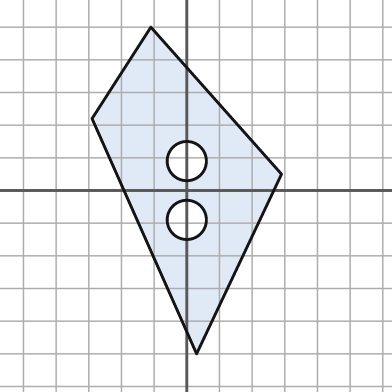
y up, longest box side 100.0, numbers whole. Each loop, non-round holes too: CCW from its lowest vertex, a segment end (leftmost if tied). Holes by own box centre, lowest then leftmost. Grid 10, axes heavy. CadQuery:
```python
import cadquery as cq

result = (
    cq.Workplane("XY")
    .moveTo(3.0, -50.0)
    .lineTo(29.0, 5.0)
    .lineTo(-11.0, 50.0)
    .lineTo(-29.0, 22.0)
    .close()
    .moveTo(0.0, -9.0)
    .circle(6.0)
    .moveTo(0.0, 9.0)
    .circle(6.0)
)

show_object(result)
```